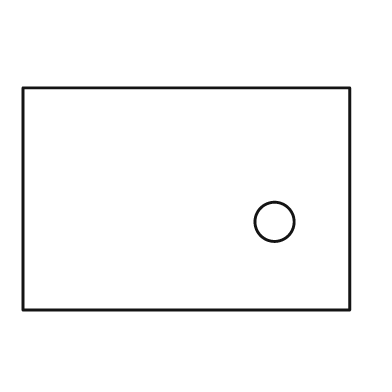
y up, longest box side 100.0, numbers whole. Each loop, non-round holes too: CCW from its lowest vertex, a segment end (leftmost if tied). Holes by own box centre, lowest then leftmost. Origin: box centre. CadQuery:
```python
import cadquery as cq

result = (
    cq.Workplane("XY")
    .moveTo(-50.0, -34.0)
    .lineTo(50.0, -34.0)
    .lineTo(50.0, 34.0)
    .lineTo(-50.0, 34.0)
    .close()
    .moveTo(27.0, -7.0)
    .circle(6.0)
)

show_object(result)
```